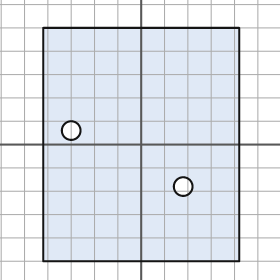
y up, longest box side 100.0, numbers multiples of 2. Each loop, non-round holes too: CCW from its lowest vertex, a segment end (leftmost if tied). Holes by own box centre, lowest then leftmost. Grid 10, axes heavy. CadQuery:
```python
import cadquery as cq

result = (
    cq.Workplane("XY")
    .moveTo(-42.0, -50.0)
    .lineTo(42.0, -50.0)
    .lineTo(42.0, 50.0)
    .lineTo(-42.0, 50.0)
    .close()
    .moveTo(18.0, -18.0)
    .circle(4.0)
    .moveTo(-30.0, 6.0)
    .circle(4.0)
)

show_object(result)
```